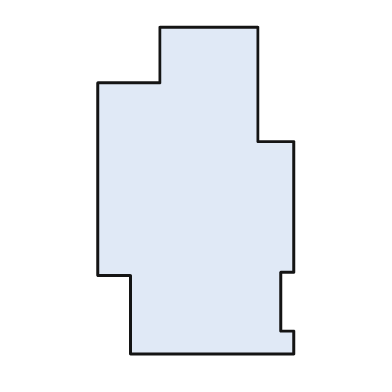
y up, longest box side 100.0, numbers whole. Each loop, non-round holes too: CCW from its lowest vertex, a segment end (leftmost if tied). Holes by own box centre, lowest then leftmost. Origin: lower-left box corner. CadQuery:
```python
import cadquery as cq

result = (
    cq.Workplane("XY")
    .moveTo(10.0, 0.0)
    .lineTo(60.0, 0.0)
    .lineTo(60.0, 7.0)
    .lineTo(56.0, 7.0)
    .lineTo(56.0, 25.0)
    .lineTo(60.0, 25.0)
    .lineTo(60.0, 65.0)
    .lineTo(49.0, 65.0)
    .lineTo(49.0, 100.0)
    .lineTo(19.0, 100.0)
    .lineTo(19.0, 83.0)
    .lineTo(0.0, 83.0)
    .lineTo(0.0, 24.0)
    .lineTo(10.0, 24.0)
    .close()
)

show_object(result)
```